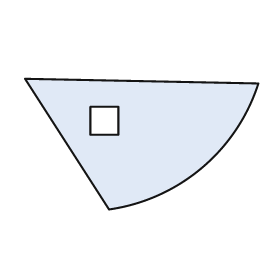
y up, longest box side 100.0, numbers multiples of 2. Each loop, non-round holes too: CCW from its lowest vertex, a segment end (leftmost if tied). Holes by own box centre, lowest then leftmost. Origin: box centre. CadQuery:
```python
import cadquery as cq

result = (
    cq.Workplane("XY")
    .moveTo(-14.0, -28.0)
    .threePointArc((26.0, -10.0), (50.0, 26.0))
    .lineTo(-50.0, 28.0)
    .close()
    .moveTo(-22.0, 4.0)
    .lineTo(-10.0, 4.0)
    .lineTo(-10.0, 16.0)
    .lineTo(-22.0, 16.0)
    .close()
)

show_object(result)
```